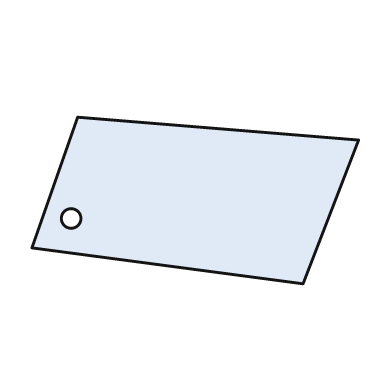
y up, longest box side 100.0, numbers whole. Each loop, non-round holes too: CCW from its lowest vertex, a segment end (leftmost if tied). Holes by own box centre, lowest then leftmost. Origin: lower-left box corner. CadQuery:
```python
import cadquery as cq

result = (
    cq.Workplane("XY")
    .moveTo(83.0, 0.0)
    .lineTo(100.0, 44.0)
    .lineTo(14.0, 51.0)
    .lineTo(0.0, 11.0)
    .close()
    .moveTo(12.0, 20.0)
    .circle(3.0)
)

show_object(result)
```